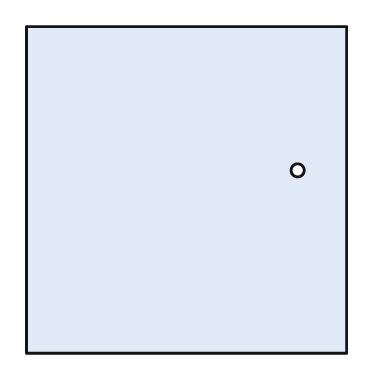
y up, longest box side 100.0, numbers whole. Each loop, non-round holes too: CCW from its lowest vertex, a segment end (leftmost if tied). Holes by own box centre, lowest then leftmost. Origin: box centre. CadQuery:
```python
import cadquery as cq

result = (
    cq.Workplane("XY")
    .moveTo(-49.0, -50.0)
    .lineTo(49.0, -50.0)
    .lineTo(49.0, 50.0)
    .lineTo(-49.0, 50.0)
    .close()
    .moveTo(34.0, 6.0)
    .circle(2.0)
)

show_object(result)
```